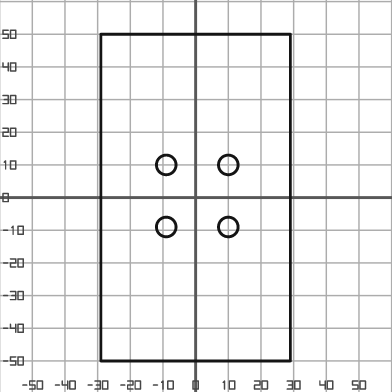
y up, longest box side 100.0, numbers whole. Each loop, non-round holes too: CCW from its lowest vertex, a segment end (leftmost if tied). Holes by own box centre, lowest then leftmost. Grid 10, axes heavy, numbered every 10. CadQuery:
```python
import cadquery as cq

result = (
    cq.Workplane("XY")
    .moveTo(-29.0, -50.0)
    .lineTo(29.0, -50.0)
    .lineTo(29.0, 50.0)
    .lineTo(-29.0, 50.0)
    .close()
    .moveTo(-9.0, -9.0)
    .circle(3.0)
    .moveTo(10.0, -9.0)
    .circle(3.0)
    .moveTo(-9.0, 10.0)
    .circle(3.0)
    .moveTo(10.0, 10.0)
    .circle(3.0)
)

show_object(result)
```